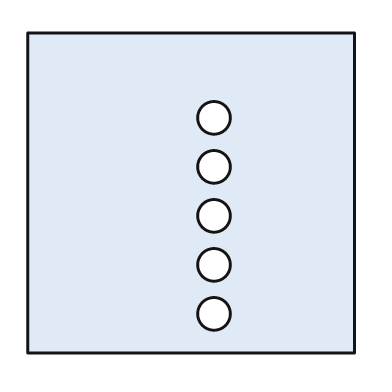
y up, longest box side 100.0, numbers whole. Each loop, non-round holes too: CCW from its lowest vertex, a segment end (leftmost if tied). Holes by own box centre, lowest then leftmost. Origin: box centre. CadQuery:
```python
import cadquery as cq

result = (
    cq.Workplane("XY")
    .moveTo(-50.0, -49.0)
    .lineTo(50.0, -49.0)
    .lineTo(50.0, 49.0)
    .lineTo(-50.0, 49.0)
    .close()
    .moveTo(7.0, -37.0)
    .circle(5.0)
    .moveTo(7.0, -22.0)
    .circle(5.0)
    .moveTo(7.0, -7.0)
    .circle(5.0)
    .moveTo(7.0, 8.0)
    .circle(5.0)
    .moveTo(7.0, 23.0)
    .circle(5.0)
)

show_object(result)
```